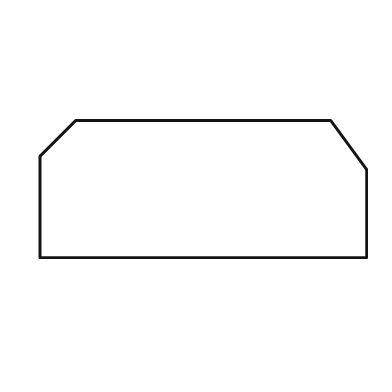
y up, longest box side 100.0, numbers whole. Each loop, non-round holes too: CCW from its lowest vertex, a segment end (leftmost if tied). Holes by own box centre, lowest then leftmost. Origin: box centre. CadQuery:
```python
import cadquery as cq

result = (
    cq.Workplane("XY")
    .moveTo(-50.0, -21.0)
    .lineTo(50.0, -21.0)
    .lineTo(50.0, 6.0)
    .lineTo(39.0, 21.0)
    .lineTo(-39.0, 21.0)
    .lineTo(-50.0, 10.0)
    .close()
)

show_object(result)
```